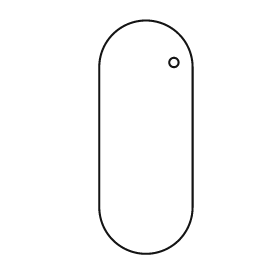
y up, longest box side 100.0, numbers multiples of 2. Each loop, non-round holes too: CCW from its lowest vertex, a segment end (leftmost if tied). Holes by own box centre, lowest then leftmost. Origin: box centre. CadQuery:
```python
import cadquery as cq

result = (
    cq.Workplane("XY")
    .moveTo(-20.0, -30.0)
    .threePointArc((0.0, -50.0), (20.0, -30.0))
    .lineTo(20.0, 30.0)
    .threePointArc((0.0, 50.0), (-20.0, 30.0))
    .close()
    .moveTo(12.0, 32.0)
    .circle(2.0)
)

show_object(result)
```